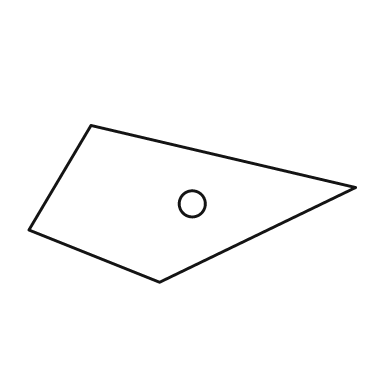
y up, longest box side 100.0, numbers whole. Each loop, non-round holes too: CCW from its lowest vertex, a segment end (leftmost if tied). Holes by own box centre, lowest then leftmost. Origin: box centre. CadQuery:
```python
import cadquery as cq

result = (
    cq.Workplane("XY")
    .moveTo(-10.0, -24.0)
    .lineTo(50.0, 5.0)
    .lineTo(-31.0, 24.0)
    .lineTo(-50.0, -8.0)
    .close()
    .moveTo(0.0, 0.0)
    .circle(4.0)
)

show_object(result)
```